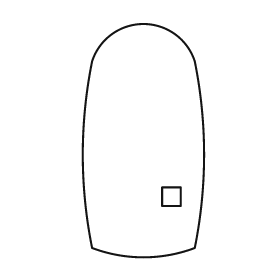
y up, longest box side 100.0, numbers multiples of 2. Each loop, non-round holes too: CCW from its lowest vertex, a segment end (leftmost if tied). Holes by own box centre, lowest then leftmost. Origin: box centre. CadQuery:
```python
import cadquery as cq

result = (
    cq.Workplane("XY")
    .moveTo(-22.0, -46.0)
    .threePointArc((0.0, -50.0), (22.0, -46.0))
    .threePointArc((26.0, -6.0), (22.0, 34.0))
    .threePointArc((0.0, 50.0), (-22.0, 34.0))
    .threePointArc((-26.0, -6.0), (-22.0, -46.0))
    .close()
    .moveTo(8.0, -28.0)
    .lineTo(16.0, -28.0)
    .lineTo(16.0, -20.0)
    .lineTo(8.0, -20.0)
    .close()
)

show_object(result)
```